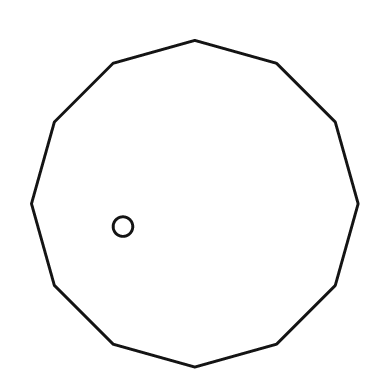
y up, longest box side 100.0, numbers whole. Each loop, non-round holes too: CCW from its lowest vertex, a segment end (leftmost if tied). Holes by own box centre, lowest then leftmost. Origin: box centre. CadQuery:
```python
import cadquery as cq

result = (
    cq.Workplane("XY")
    .moveTo(0.0, -50.0)
    .lineTo(25.0, -43.0)
    .lineTo(43.0, -25.0)
    .lineTo(50.0, 0.0)
    .lineTo(43.0, 25.0)
    .lineTo(25.0, 43.0)
    .lineTo(0.0, 50.0)
    .lineTo(-25.0, 43.0)
    .lineTo(-43.0, 25.0)
    .lineTo(-50.0, 0.0)
    .lineTo(-43.0, -25.0)
    .lineTo(-25.0, -43.0)
    .close()
    .moveTo(-22.0, -7.0)
    .circle(3.0)
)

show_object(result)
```